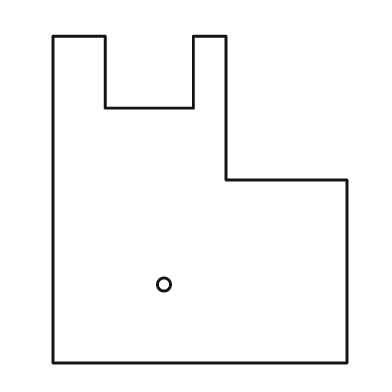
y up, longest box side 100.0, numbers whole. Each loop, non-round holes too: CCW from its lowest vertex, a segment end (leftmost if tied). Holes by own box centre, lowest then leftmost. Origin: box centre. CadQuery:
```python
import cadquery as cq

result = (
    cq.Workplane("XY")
    .moveTo(-45.0, -50.0)
    .lineTo(45.0, -50.0)
    .lineTo(45.0, 6.0)
    .lineTo(8.0, 6.0)
    .lineTo(8.0, 50.0)
    .lineTo(-2.0, 50.0)
    .lineTo(-2.0, 28.0)
    .lineTo(-29.0, 28.0)
    .lineTo(-29.0, 50.0)
    .lineTo(-45.0, 50.0)
    .close()
    .moveTo(-11.0, -26.0)
    .circle(2.0)
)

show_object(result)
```